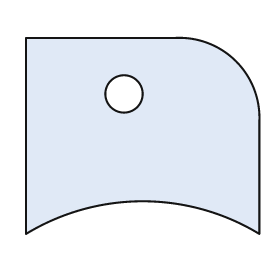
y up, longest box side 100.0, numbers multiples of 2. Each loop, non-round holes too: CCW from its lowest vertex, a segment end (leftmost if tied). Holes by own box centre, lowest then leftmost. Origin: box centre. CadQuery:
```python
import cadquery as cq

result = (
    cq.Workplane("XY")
    .moveTo(-50.0, -42.0)
    .threePointArc((0.0, -28.0), (50.0, -42.0))
    .lineTo(50.0, 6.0)
    .threePointArc((40.0, 32.0), (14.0, 42.0))
    .lineTo(-50.0, 42.0)
    .close()
    .moveTo(-8.0, 18.0)
    .circle(8.0)
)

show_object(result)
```